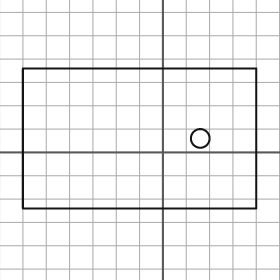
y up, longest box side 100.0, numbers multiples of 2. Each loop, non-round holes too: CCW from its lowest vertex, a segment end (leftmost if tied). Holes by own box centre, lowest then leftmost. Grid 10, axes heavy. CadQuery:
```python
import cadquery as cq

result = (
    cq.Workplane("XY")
    .moveTo(-60.0, -24.0)
    .lineTo(40.0, -24.0)
    .lineTo(40.0, 36.0)
    .lineTo(-60.0, 36.0)
    .close()
    .moveTo(16.0, 6.0)
    .circle(4.0)
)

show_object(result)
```